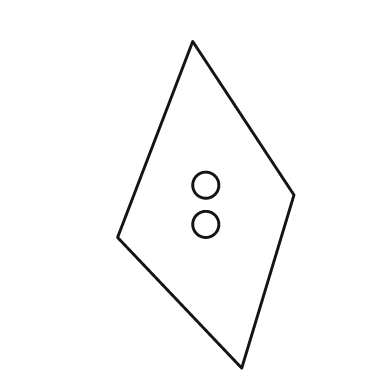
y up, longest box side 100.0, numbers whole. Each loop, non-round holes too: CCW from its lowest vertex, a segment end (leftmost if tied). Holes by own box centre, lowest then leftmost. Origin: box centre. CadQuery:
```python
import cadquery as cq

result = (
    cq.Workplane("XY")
    .moveTo(11.0, -50.0)
    .lineTo(27.0, 3.0)
    .lineTo(-4.0, 50.0)
    .lineTo(-27.0, -10.0)
    .close()
    .moveTo(0.0, -6.0)
    .circle(4.0)
    .moveTo(0.0, 6.0)
    .circle(4.0)
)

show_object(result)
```